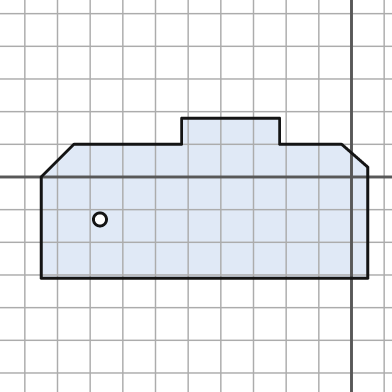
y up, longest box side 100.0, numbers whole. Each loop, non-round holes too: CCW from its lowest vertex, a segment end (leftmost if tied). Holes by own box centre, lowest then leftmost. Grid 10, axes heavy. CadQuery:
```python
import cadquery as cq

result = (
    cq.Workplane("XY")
    .moveTo(-95.0, -31.0)
    .lineTo(5.0, -31.0)
    .lineTo(5.0, 3.0)
    .lineTo(-3.0, 10.0)
    .lineTo(-22.0, 10.0)
    .lineTo(-22.0, 18.0)
    .lineTo(-52.0, 18.0)
    .lineTo(-52.0, 10.0)
    .lineTo(-85.0, 10.0)
    .lineTo(-95.0, 0.0)
    .close()
    .moveTo(-77.0, -13.0)
    .circle(2.0)
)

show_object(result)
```